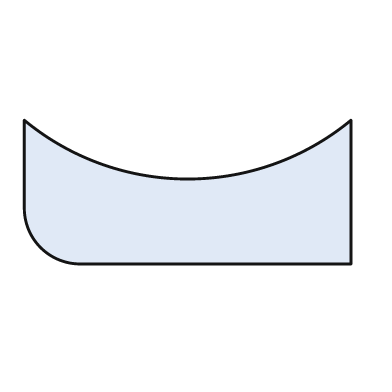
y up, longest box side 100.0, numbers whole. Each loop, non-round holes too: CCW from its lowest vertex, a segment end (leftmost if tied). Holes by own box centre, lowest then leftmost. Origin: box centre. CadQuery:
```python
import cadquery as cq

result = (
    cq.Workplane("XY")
    .moveTo(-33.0, -22.0)
    .lineTo(50.0, -22.0)
    .lineTo(50.0, 22.0)
    .threePointArc((0.0, 4.0), (-50.0, 22.0))
    .lineTo(-50.0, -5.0)
    .threePointArc((-45.0, -17.0), (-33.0, -22.0))
    .close()
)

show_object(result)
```